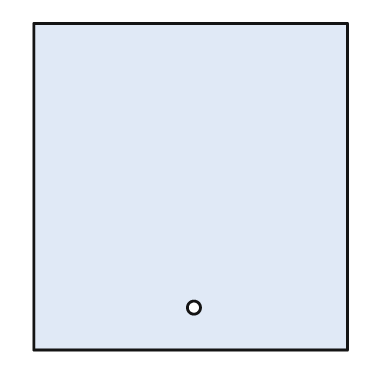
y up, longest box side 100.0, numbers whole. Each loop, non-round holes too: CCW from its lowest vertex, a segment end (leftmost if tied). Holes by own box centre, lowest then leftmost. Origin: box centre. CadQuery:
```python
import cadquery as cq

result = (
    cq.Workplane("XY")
    .moveTo(-48.0, -50.0)
    .lineTo(48.0, -50.0)
    .lineTo(48.0, 50.0)
    .lineTo(-48.0, 50.0)
    .close()
    .moveTo(1.0, -37.0)
    .circle(2.0)
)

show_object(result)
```